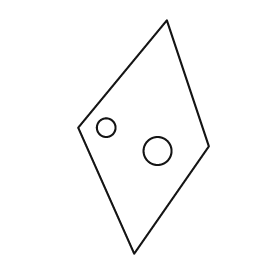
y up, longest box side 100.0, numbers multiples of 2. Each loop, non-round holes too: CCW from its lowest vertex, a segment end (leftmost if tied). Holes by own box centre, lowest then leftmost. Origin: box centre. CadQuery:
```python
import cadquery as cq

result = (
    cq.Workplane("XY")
    .moveTo(-4.0, -50.0)
    .lineTo(28.0, -4.0)
    .lineTo(10.0, 50.0)
    .lineTo(-28.0, 4.0)
    .close()
    .moveTo(6.0, -6.0)
    .circle(6.0)
    .moveTo(-16.0, 4.0)
    .circle(4.0)
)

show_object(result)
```